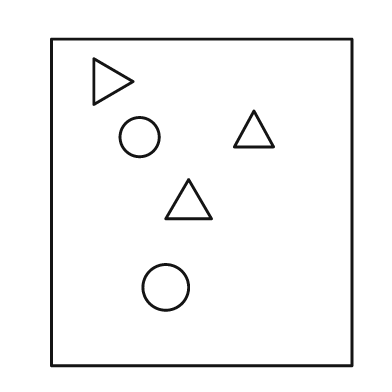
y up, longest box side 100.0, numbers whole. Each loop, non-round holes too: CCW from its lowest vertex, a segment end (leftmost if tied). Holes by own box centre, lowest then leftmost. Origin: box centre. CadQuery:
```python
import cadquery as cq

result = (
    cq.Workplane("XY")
    .moveTo(-46.0, -50.0)
    .lineTo(46.0, -50.0)
    .lineTo(46.0, 50.0)
    .lineTo(-46.0, 50.0)
    .close()
    .moveTo(-11.0, -26.0)
    .circle(7.0)
    .moveTo(-11.0, -5.0)
    .lineTo(3.0, -5.0)
    .lineTo(-4.0, 7.0)
    .close()
    .moveTo(-19.0, 20.0)
    .circle(6.0)
    .moveTo(10.0, 17.0)
    .lineTo(22.0, 17.0)
    .lineTo(16.0, 28.0)
    .close()
    .moveTo(-33.0, 30.0)
    .lineTo(-21.0, 37.0)
    .lineTo(-33.0, 44.0)
    .close()
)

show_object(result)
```